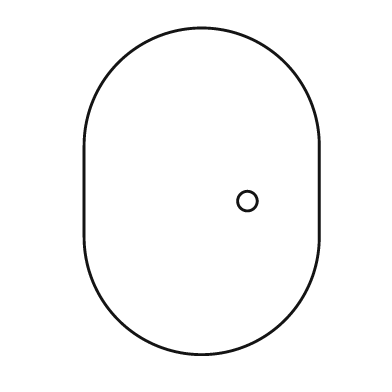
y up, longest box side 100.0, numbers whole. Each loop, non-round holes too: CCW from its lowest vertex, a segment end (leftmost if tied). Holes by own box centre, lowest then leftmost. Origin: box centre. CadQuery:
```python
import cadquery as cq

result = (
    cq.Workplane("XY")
    .moveTo(-36.0, -14.0)
    .threePointArc((0.0, -50.0), (36.0, -14.0))
    .lineTo(36.0, 14.0)
    .threePointArc((0.0, 50.0), (-36.0, 14.0))
    .close()
    .moveTo(14.0, -3.0)
    .circle(3.0)
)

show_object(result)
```